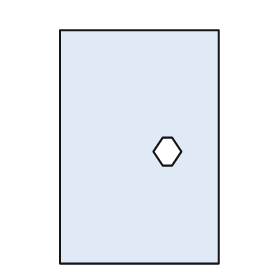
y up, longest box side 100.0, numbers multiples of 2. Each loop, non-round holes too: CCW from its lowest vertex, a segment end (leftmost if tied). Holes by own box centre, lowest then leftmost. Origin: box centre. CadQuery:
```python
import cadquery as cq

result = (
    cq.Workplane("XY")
    .moveTo(-34.0, -50.0)
    .lineTo(34.0, -50.0)
    .lineTo(34.0, 50.0)
    .lineTo(-34.0, 50.0)
    .close()
    .moveTo(10.0, -8.0)
    .lineTo(14.0, -8.0)
    .lineTo(18.0, -2.0)
    .lineTo(14.0, 4.0)
    .lineTo(10.0, 4.0)
    .lineTo(6.0, -2.0)
    .close()
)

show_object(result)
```